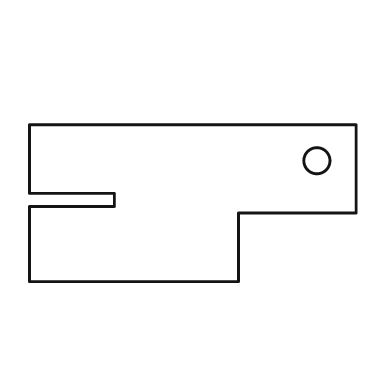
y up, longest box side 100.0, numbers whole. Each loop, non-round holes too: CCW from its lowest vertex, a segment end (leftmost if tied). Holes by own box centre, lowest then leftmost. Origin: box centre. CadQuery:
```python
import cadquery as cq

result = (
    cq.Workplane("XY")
    .moveTo(-50.0, -24.0)
    .lineTo(14.0, -24.0)
    .lineTo(14.0, -3.0)
    .lineTo(50.0, -3.0)
    .lineTo(50.0, 24.0)
    .lineTo(-50.0, 24.0)
    .lineTo(-50.0, 3.0)
    .lineTo(-24.0, 3.0)
    .lineTo(-24.0, -1.0)
    .lineTo(-50.0, -1.0)
    .close()
    .moveTo(38.0, 13.0)
    .circle(4.0)
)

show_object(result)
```